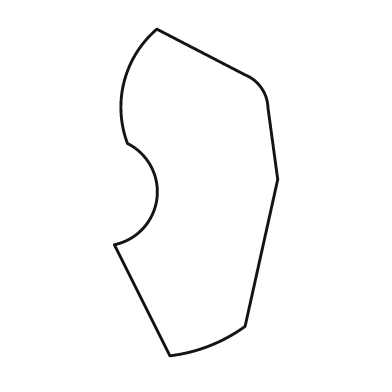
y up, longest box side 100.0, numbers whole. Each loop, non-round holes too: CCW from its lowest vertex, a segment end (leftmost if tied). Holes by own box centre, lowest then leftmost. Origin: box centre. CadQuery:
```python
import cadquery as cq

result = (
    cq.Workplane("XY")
    .moveTo(-8.0, -50.0)
    .threePointArc((4.0, -47.0), (15.0, -41.0))
    .lineTo(25.0, 4.0)
    .lineTo(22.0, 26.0)
    .threePointArc((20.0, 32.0), (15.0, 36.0))
    .lineTo(-12.0, 50.0)
    .threePointArc((-22.0, 34.0), (-21.0, 15.0))
    .threePointArc((-12.0, -2.0), (-25.0, -16.0))
    .close()
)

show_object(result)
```